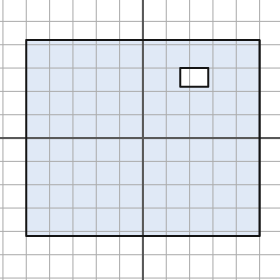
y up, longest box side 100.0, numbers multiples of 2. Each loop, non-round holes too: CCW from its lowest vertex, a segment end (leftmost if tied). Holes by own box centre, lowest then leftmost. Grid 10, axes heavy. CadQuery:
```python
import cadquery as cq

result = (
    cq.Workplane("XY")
    .moveTo(-50.0, -42.0)
    .lineTo(50.0, -42.0)
    .lineTo(50.0, 42.0)
    .lineTo(-50.0, 42.0)
    .close()
    .moveTo(16.0, 22.0)
    .lineTo(28.0, 22.0)
    .lineTo(28.0, 30.0)
    .lineTo(16.0, 30.0)
    .close()
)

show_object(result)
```